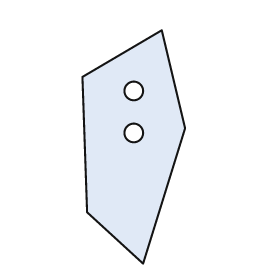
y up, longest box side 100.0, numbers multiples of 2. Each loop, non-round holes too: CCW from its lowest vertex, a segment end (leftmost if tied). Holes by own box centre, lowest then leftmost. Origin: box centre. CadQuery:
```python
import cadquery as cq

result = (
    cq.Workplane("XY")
    .moveTo(4.0, -50.0)
    .lineTo(22.0, 8.0)
    .lineTo(12.0, 50.0)
    .lineTo(-22.0, 30.0)
    .lineTo(-20.0, -28.0)
    .close()
    .moveTo(0.0, 6.0)
    .circle(4.0)
    .moveTo(0.0, 24.0)
    .circle(4.0)
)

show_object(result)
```